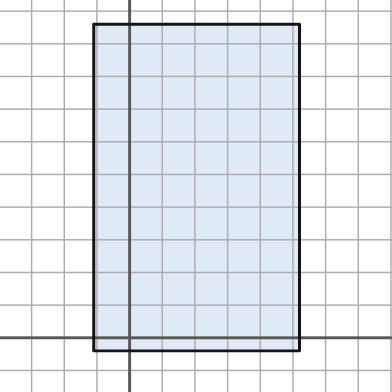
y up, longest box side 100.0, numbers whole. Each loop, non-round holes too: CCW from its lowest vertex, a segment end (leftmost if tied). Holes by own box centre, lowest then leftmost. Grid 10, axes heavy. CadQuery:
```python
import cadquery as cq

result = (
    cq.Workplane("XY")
    .moveTo(-11.0, -4.0)
    .lineTo(52.0, -4.0)
    .lineTo(52.0, 96.0)
    .lineTo(-11.0, 96.0)
    .close()
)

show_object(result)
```